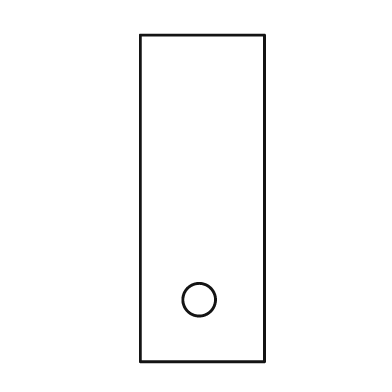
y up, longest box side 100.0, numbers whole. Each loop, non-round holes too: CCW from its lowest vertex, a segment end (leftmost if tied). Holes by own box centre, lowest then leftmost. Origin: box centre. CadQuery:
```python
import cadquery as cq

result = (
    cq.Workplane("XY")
    .moveTo(-19.0, -50.0)
    .lineTo(19.0, -50.0)
    .lineTo(19.0, 50.0)
    .lineTo(-19.0, 50.0)
    .close()
    .moveTo(-1.0, -31.0)
    .circle(5.0)
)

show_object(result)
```